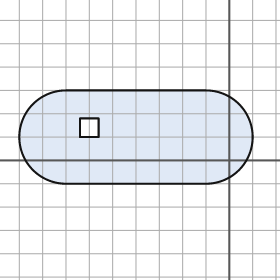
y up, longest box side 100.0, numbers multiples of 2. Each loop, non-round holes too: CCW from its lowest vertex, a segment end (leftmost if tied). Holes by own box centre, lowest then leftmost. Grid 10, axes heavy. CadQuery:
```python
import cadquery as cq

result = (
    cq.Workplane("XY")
    .moveTo(-70.0, -10.0)
    .lineTo(-10.0, -10.0)
    .threePointArc((10.0, 10.0), (-10.0, 30.0))
    .lineTo(-70.0, 30.0)
    .threePointArc((-90.0, 10.0), (-70.0, -10.0))
    .close()
    .moveTo(-64.0, 10.0)
    .lineTo(-56.0, 10.0)
    .lineTo(-56.0, 18.0)
    .lineTo(-64.0, 18.0)
    .close()
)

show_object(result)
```